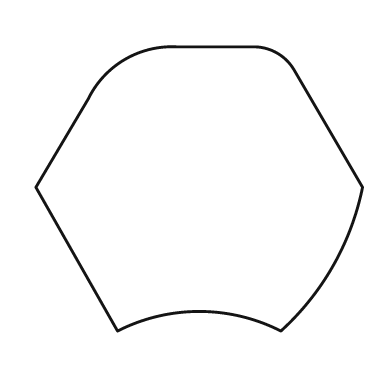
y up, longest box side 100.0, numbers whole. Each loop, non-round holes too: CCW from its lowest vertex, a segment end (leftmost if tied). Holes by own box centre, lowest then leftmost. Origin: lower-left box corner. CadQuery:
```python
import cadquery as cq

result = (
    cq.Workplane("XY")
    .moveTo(25.0, 0.0)
    .threePointArc((50.0, 6.0), (75.0, 0.0))
    .threePointArc((91.0, 20.0), (100.0, 44.0))
    .lineTo(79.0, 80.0)
    .threePointArc((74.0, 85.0), (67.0, 87.0))
    .lineTo(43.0, 87.0)
    .threePointArc((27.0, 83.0), (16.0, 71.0))
    .lineTo(0.0, 44.0)
    .close()
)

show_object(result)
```